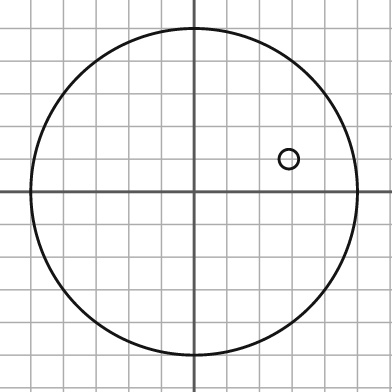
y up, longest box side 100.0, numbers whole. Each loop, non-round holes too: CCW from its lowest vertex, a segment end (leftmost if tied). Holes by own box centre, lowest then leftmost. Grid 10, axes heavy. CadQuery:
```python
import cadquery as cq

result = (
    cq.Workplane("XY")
    .moveTo(0.0, 0.0)
    .circle(50.0)
    .moveTo(29.0, 10.0)
    .circle(3.0)
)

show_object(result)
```